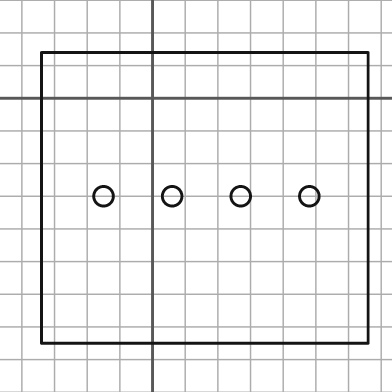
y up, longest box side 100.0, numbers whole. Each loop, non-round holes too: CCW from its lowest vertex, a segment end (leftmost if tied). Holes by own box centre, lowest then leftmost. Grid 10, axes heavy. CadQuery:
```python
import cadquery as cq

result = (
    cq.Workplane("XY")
    .moveTo(-34.0, -75.0)
    .lineTo(66.0, -75.0)
    .lineTo(66.0, 14.0)
    .lineTo(-34.0, 14.0)
    .close()
    .moveTo(-15.0, -30.0)
    .circle(3.0)
    .moveTo(6.0, -30.0)
    .circle(3.0)
    .moveTo(27.0, -30.0)
    .circle(3.0)
    .moveTo(48.0, -30.0)
    .circle(3.0)
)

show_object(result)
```